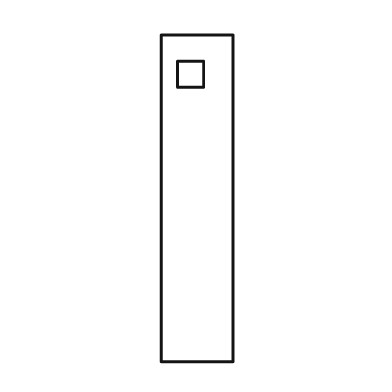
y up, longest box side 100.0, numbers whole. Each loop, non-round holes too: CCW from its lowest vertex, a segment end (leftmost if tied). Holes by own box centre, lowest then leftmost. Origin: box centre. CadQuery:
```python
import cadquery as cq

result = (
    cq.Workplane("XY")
    .moveTo(-11.0, -50.0)
    .lineTo(11.0, -50.0)
    .lineTo(11.0, 50.0)
    .lineTo(-11.0, 50.0)
    .close()
    .moveTo(-6.0, 34.0)
    .lineTo(2.0, 34.0)
    .lineTo(2.0, 42.0)
    .lineTo(-6.0, 42.0)
    .close()
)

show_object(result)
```